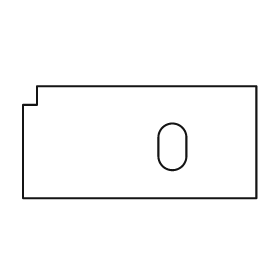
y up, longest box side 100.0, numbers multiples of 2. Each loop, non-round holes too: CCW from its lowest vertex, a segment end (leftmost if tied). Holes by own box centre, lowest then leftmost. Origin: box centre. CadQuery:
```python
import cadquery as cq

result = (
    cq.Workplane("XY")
    .moveTo(-50.0, -24.0)
    .lineTo(50.0, -24.0)
    .lineTo(50.0, 24.0)
    .lineTo(-44.0, 24.0)
    .lineTo(-44.0, 16.0)
    .lineTo(-50.0, 16.0)
    .close()
    .moveTo(8.0, -6.0)
    .threePointArc((14.0, -12.0), (20.0, -6.0))
    .lineTo(20.0, 2.0)
    .threePointArc((14.0, 8.0), (8.0, 2.0))
    .close()
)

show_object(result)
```